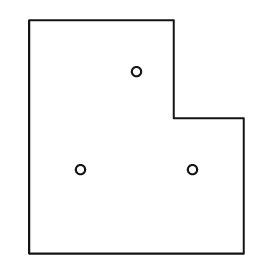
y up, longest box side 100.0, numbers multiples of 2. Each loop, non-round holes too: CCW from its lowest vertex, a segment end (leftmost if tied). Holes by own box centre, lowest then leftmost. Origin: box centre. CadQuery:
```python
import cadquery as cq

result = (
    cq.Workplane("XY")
    .moveTo(-46.0, -50.0)
    .lineTo(46.0, -50.0)
    .lineTo(46.0, 8.0)
    .lineTo(16.0, 8.0)
    .lineTo(16.0, 50.0)
    .lineTo(-46.0, 50.0)
    .close()
    .moveTo(-24.0, -14.0)
    .circle(2.0)
    .moveTo(24.0, -14.0)
    .circle(2.0)
    .moveTo(0.0, 28.0)
    .circle(2.0)
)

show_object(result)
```